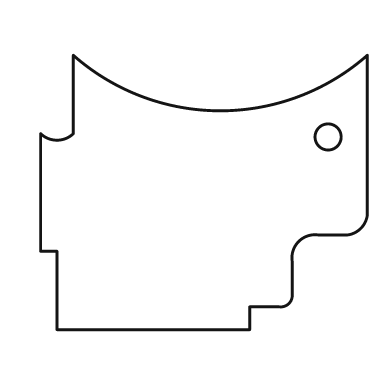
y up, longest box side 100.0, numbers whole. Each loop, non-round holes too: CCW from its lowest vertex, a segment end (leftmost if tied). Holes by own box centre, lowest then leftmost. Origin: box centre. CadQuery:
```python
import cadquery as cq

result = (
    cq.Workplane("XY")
    .moveTo(-45.0, -42.0)
    .lineTo(14.0, -42.0)
    .lineTo(14.0, -35.0)
    .lineTo(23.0, -35.0)
    .threePointArc((26.0, -34.0), (27.0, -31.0))
    .lineTo(27.0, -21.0)
    .threePointArc((29.0, -15.0), (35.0, -13.0))
    .lineTo(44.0, -13.0)
    .threePointArc((48.0, -11.0), (50.0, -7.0))
    .lineTo(50.0, 42.0)
    .threePointArc((5.0, 25.0), (-40.0, 42.0))
    .lineTo(-40.0, 18.0)
    .threePointArc((-45.0, 16.0), (-50.0, 18.0))
    .lineTo(-50.0, -18.0)
    .lineTo(-45.0, -18.0)
    .close()
    .moveTo(38.0, 17.0)
    .circle(4.0)
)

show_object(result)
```